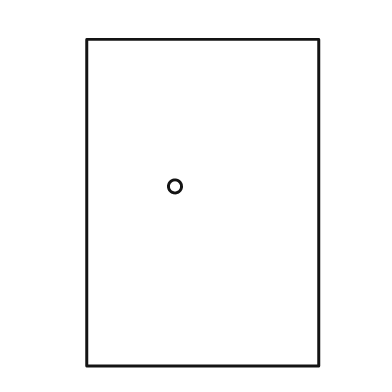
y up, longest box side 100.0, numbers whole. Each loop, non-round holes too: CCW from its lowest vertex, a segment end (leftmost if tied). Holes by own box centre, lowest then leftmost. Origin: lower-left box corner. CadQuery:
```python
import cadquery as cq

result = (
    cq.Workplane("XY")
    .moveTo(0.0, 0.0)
    .lineTo(71.0, 0.0)
    .lineTo(71.0, 100.0)
    .lineTo(0.0, 100.0)
    .close()
    .moveTo(27.0, 55.0)
    .circle(2.0)
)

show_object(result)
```